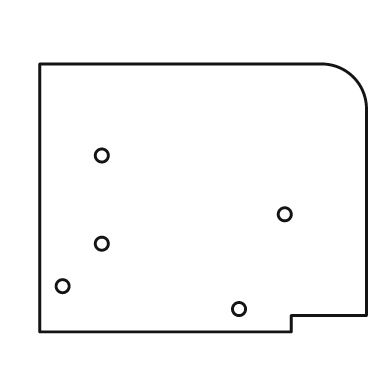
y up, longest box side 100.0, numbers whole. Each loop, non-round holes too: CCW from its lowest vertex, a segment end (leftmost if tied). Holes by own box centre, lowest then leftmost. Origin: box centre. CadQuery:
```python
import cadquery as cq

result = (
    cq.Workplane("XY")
    .moveTo(-50.0, -41.0)
    .lineTo(27.0, -41.0)
    .lineTo(27.0, -36.0)
    .lineTo(50.0, -36.0)
    .lineTo(50.0, 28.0)
    .threePointArc((46.0, 37.0), (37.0, 41.0))
    .lineTo(-50.0, 41.0)
    .close()
    .moveTo(11.0, -34.0)
    .circle(2.0)
    .moveTo(-43.0, -27.0)
    .circle(2.0)
    .moveTo(-31.0, -14.0)
    .circle(2.0)
    .moveTo(25.0, -5.0)
    .circle(2.0)
    .moveTo(-31.0, 13.0)
    .circle(2.0)
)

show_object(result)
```